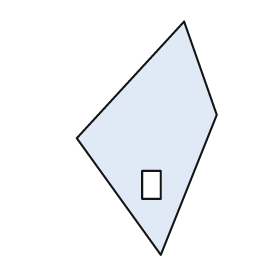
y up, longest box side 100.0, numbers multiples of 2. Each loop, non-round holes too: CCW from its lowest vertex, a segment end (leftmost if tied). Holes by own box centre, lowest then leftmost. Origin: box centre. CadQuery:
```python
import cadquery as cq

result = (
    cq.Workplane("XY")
    .moveTo(6.0, -50.0)
    .lineTo(30.0, 10.0)
    .lineTo(16.0, 50.0)
    .lineTo(-30.0, 0.0)
    .close()
    .moveTo(-2.0, -26.0)
    .lineTo(6.0, -26.0)
    .lineTo(6.0, -14.0)
    .lineTo(-2.0, -14.0)
    .close()
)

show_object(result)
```